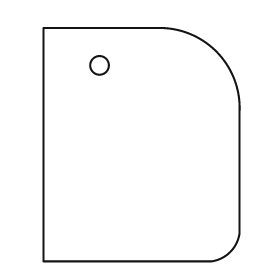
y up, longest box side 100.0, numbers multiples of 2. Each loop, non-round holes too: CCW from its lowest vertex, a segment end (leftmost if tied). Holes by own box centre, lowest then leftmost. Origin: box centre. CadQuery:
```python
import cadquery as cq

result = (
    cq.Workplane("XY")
    .moveTo(-42.0, -50.0)
    .lineTo(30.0, -50.0)
    .threePointArc((38.0, -46.0), (42.0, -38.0))
    .lineTo(42.0, 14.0)
    .threePointArc((32.0, 40.0), (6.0, 50.0))
    .lineTo(-42.0, 50.0)
    .close()
    .moveTo(-18.0, 34.0)
    .circle(4.0)
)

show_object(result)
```